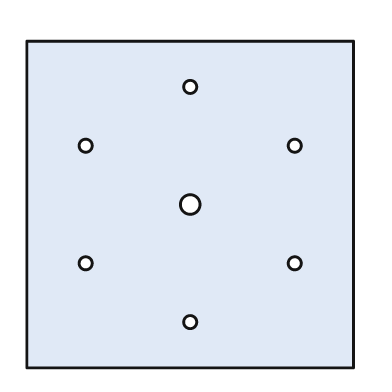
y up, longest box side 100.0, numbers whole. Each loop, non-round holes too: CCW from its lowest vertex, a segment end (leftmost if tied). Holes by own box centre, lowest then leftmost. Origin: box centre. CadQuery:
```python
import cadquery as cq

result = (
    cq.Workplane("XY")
    .moveTo(-50.0, -50.0)
    .lineTo(50.0, -50.0)
    .lineTo(50.0, 50.0)
    .lineTo(-50.0, 50.0)
    .close()
    .moveTo(0.0, -36.0)
    .circle(2.0)
    .moveTo(-32.0, -18.0)
    .circle(2.0)
    .moveTo(32.0, -18.0)
    .circle(2.0)
    .moveTo(0.0, 0.0)
    .circle(3.0)
    .moveTo(-32.0, 18.0)
    .circle(2.0)
    .moveTo(32.0, 18.0)
    .circle(2.0)
    .moveTo(0.0, 36.0)
    .circle(2.0)
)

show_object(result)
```